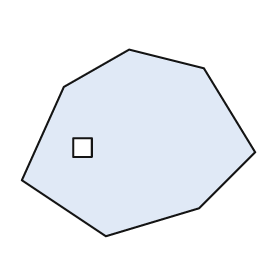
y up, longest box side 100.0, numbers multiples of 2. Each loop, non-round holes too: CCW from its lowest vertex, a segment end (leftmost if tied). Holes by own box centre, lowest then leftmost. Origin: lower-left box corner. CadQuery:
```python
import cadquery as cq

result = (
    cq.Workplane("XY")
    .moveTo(36.0, 0.0)
    .lineTo(76.0, 12.0)
    .lineTo(100.0, 36.0)
    .lineTo(78.0, 72.0)
    .lineTo(46.0, 80.0)
    .lineTo(18.0, 64.0)
    .lineTo(0.0, 24.0)
    .close()
    .moveTo(22.0, 34.0)
    .lineTo(30.0, 34.0)
    .lineTo(30.0, 42.0)
    .lineTo(22.0, 42.0)
    .close()
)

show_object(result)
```